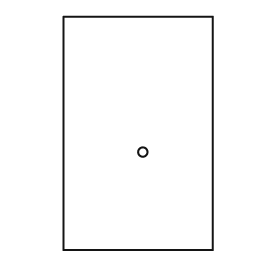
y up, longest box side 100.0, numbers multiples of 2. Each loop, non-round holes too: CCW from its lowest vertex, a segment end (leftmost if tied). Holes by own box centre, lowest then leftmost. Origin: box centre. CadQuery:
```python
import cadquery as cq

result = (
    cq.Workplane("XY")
    .moveTo(-32.0, -50.0)
    .lineTo(32.0, -50.0)
    .lineTo(32.0, 50.0)
    .lineTo(-32.0, 50.0)
    .close()
    .moveTo(2.0, -8.0)
    .circle(2.0)
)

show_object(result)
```